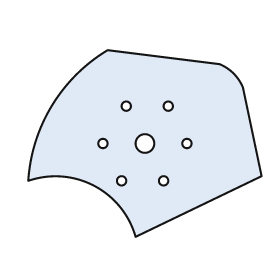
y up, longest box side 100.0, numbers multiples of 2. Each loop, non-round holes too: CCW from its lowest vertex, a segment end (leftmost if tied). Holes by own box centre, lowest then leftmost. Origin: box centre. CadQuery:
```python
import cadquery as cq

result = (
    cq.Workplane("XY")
    .moveTo(-4.0, -40.0)
    .lineTo(50.0, -14.0)
    .lineTo(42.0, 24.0)
    .threePointArc((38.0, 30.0), (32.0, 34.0))
    .lineTo(-16.0, 40.0)
    .threePointArc((-40.0, 16.0), (-50.0, -16.0))
    .threePointArc((-22.0, -18.0), (-4.0, -40.0))
    .close()
    .moveTo(-10.0, -16.0)
    .circle(2.0)
    .moveTo(8.0, -16.0)
    .circle(2.0)
    .moveTo(-18.0, 0.0)
    .circle(2.0)
    .moveTo(0.0, 0.0)
    .circle(4.0)
    .moveTo(18.0, 0.0)
    .circle(2.0)
    .moveTo(-8.0, 16.0)
    .circle(2.0)
    .moveTo(10.0, 16.0)
    .circle(2.0)
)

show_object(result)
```